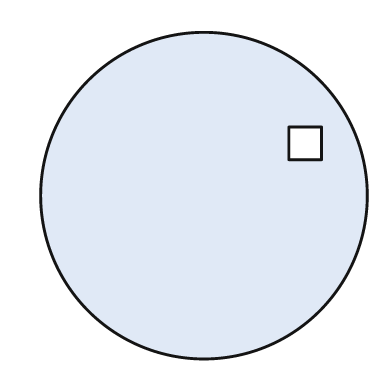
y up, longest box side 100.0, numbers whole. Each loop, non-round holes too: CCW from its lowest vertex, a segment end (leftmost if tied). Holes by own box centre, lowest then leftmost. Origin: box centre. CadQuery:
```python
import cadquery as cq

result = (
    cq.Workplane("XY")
    .moveTo(0.0, 0.0)
    .circle(50.0)
    .moveTo(26.0, 11.0)
    .lineTo(36.0, 11.0)
    .lineTo(36.0, 21.0)
    .lineTo(26.0, 21.0)
    .close()
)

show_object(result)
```